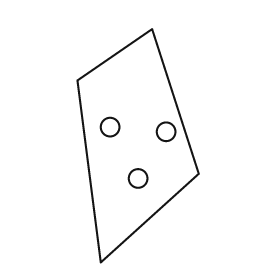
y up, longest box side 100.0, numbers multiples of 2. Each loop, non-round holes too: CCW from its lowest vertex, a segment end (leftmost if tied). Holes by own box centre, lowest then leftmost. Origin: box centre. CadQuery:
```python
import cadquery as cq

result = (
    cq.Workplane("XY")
    .moveTo(-16.0, -50.0)
    .lineTo(26.0, -12.0)
    .lineTo(6.0, 50.0)
    .lineTo(-26.0, 28.0)
    .close()
    .moveTo(0.0, -14.0)
    .circle(4.0)
    .moveTo(12.0, 6.0)
    .circle(4.0)
    .moveTo(-12.0, 8.0)
    .circle(4.0)
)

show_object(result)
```